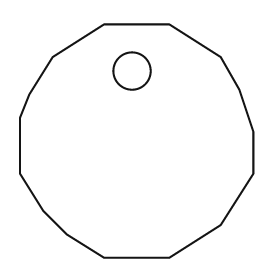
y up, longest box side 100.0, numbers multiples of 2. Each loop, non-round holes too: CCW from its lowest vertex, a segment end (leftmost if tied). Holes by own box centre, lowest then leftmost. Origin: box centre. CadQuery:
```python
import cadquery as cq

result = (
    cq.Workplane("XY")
    .moveTo(-14.0, -50.0)
    .lineTo(14.0, -50.0)
    .lineTo(36.0, -36.0)
    .lineTo(50.0, -14.0)
    .lineTo(50.0, 4.0)
    .lineTo(44.0, 22.0)
    .lineTo(36.0, 36.0)
    .lineTo(14.0, 50.0)
    .lineTo(-14.0, 50.0)
    .lineTo(-36.0, 36.0)
    .lineTo(-46.0, 20.0)
    .lineTo(-50.0, 10.0)
    .lineTo(-50.0, -14.0)
    .lineTo(-40.0, -30.0)
    .lineTo(-30.0, -40.0)
    .close()
    .moveTo(-2.0, 30.0)
    .circle(8.0)
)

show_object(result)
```